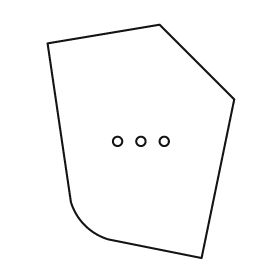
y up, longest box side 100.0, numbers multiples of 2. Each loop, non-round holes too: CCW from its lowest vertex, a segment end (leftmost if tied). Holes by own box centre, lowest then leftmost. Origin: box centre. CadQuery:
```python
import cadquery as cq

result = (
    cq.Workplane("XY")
    .moveTo(26.0, -50.0)
    .lineTo(40.0, 18.0)
    .lineTo(8.0, 50.0)
    .lineTo(-40.0, 42.0)
    .lineTo(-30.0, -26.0)
    .threePointArc((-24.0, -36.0), (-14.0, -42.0))
    .close()
    .moveTo(-10.0, 0.0)
    .circle(2.0)
    .moveTo(0.0, 0.0)
    .circle(2.0)
    .moveTo(10.0, 0.0)
    .circle(2.0)
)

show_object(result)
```